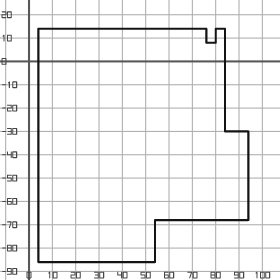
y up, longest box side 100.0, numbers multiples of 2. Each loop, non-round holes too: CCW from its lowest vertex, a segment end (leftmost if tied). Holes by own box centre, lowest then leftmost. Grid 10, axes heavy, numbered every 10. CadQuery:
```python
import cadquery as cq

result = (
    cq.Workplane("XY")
    .moveTo(4.0, -86.0)
    .lineTo(54.0, -86.0)
    .lineTo(54.0, -68.0)
    .lineTo(94.0, -68.0)
    .lineTo(94.0, -30.0)
    .lineTo(84.0, -30.0)
    .lineTo(84.0, 14.0)
    .lineTo(80.0, 14.0)
    .lineTo(80.0, 8.0)
    .lineTo(76.0, 8.0)
    .lineTo(76.0, 14.0)
    .lineTo(4.0, 14.0)
    .close()
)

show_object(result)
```